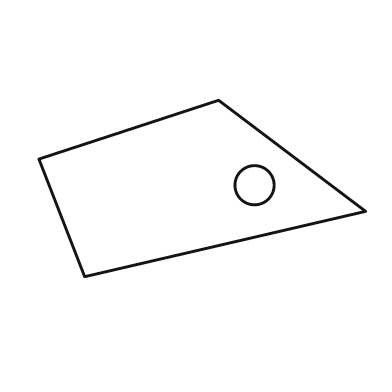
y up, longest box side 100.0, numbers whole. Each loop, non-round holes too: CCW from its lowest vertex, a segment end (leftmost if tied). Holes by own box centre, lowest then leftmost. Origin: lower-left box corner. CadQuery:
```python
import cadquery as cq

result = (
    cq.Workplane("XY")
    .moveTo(14.0, 0.0)
    .lineTo(100.0, 20.0)
    .lineTo(55.0, 54.0)
    .lineTo(0.0, 36.0)
    .close()
    .moveTo(66.0, 28.0)
    .circle(6.0)
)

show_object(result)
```